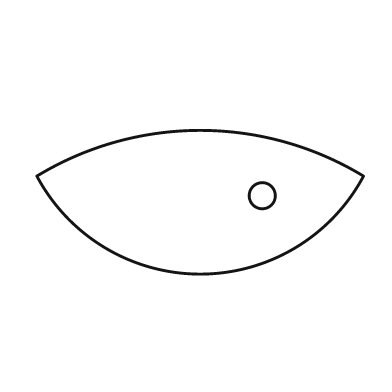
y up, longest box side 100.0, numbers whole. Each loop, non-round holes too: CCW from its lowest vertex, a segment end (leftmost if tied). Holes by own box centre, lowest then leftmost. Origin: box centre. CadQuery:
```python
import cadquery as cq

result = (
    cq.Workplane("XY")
    .moveTo(-50.0, 8.0)
    .threePointArc((0.0, -22.0), (50.0, 8.0))
    .threePointArc((0.0, 22.0), (-50.0, 8.0))
    .close()
    .moveTo(19.0, 2.0)
    .circle(4.0)
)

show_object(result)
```